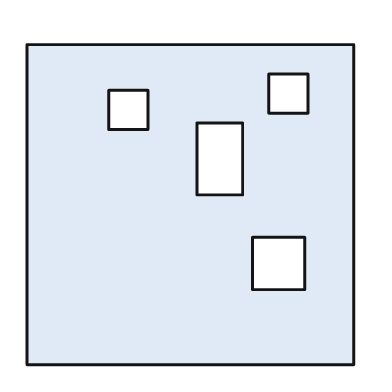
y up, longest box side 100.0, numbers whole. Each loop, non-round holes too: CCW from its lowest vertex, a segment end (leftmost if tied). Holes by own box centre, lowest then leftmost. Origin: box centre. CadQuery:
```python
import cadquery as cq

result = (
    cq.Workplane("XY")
    .moveTo(-50.0, -49.0)
    .lineTo(50.0, -49.0)
    .lineTo(50.0, 49.0)
    .lineTo(-50.0, 49.0)
    .close()
    .moveTo(19.0, -26.0)
    .lineTo(35.0, -26.0)
    .lineTo(35.0, -10.0)
    .lineTo(19.0, -10.0)
    .close()
    .moveTo(2.0, 3.0)
    .lineTo(16.0, 3.0)
    .lineTo(16.0, 25.0)
    .lineTo(2.0, 25.0)
    .close()
    .moveTo(-25.0, 23.0)
    .lineTo(-13.0, 23.0)
    .lineTo(-13.0, 35.0)
    .lineTo(-25.0, 35.0)
    .close()
    .moveTo(24.0, 28.0)
    .lineTo(36.0, 28.0)
    .lineTo(36.0, 40.0)
    .lineTo(24.0, 40.0)
    .close()
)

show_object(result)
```